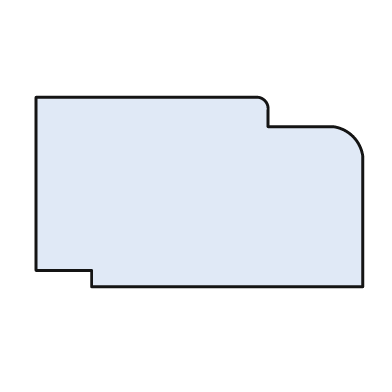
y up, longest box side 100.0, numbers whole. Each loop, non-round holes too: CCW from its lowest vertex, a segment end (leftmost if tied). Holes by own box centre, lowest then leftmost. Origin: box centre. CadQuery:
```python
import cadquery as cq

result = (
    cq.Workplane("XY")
    .moveTo(-33.0, -29.0)
    .lineTo(50.0, -29.0)
    .lineTo(50.0, 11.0)
    .threePointArc((47.0, 17.0), (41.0, 20.0))
    .lineTo(21.0, 20.0)
    .lineTo(21.0, 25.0)
    .threePointArc((20.0, 28.0), (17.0, 29.0))
    .lineTo(-50.0, 29.0)
    .lineTo(-50.0, -24.0)
    .lineTo(-33.0, -24.0)
    .close()
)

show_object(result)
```